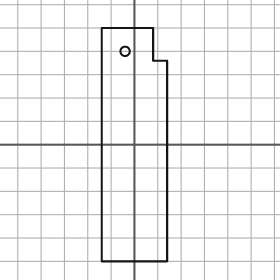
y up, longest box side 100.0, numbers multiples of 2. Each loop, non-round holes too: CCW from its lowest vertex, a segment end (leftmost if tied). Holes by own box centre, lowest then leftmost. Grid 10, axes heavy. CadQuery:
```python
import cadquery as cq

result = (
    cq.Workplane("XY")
    .moveTo(-14.0, -50.0)
    .lineTo(14.0, -50.0)
    .lineTo(14.0, 36.0)
    .lineTo(8.0, 36.0)
    .lineTo(8.0, 50.0)
    .lineTo(-14.0, 50.0)
    .close()
    .moveTo(-4.0, 40.0)
    .circle(2.0)
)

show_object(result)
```